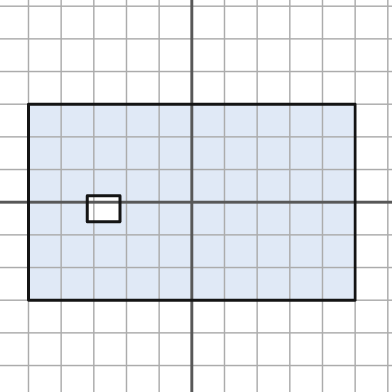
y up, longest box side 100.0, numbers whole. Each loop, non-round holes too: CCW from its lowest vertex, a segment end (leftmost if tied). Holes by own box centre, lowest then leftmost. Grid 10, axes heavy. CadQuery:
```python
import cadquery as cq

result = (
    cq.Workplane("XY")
    .moveTo(-50.0, -30.0)
    .lineTo(50.0, -30.0)
    .lineTo(50.0, 30.0)
    .lineTo(-50.0, 30.0)
    .close()
    .moveTo(-32.0, -6.0)
    .lineTo(-22.0, -6.0)
    .lineTo(-22.0, 2.0)
    .lineTo(-32.0, 2.0)
    .close()
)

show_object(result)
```